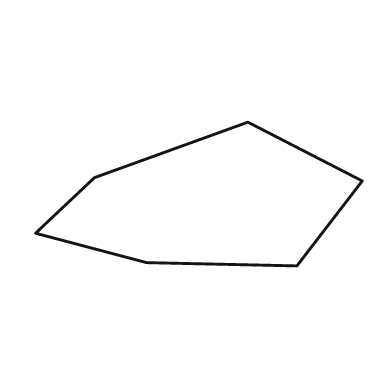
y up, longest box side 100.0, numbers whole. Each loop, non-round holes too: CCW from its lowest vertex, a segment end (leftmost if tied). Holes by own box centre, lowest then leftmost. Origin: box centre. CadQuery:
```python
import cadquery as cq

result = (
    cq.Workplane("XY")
    .moveTo(30.0, -22.0)
    .lineTo(50.0, 4.0)
    .lineTo(15.0, 22.0)
    .lineTo(-32.0, 5.0)
    .lineTo(-50.0, -12.0)
    .lineTo(-16.0, -21.0)
    .close()
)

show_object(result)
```